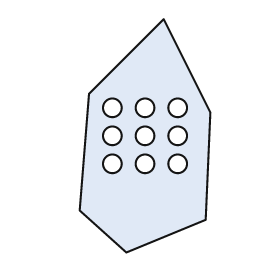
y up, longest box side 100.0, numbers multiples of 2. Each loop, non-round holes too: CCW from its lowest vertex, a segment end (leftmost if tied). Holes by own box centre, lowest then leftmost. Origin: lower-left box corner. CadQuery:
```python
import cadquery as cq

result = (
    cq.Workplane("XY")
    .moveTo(20.0, 0.0)
    .lineTo(54.0, 14.0)
    .lineTo(56.0, 60.0)
    .lineTo(36.0, 100.0)
    .lineTo(4.0, 68.0)
    .lineTo(0.0, 18.0)
    .close()
    .moveTo(14.0, 38.0)
    .circle(4.0)
    .moveTo(28.0, 38.0)
    .circle(4.0)
    .moveTo(42.0, 38.0)
    .circle(4.0)
    .moveTo(14.0, 50.0)
    .circle(4.0)
    .moveTo(28.0, 50.0)
    .circle(4.0)
    .moveTo(42.0, 50.0)
    .circle(4.0)
    .moveTo(14.0, 62.0)
    .circle(4.0)
    .moveTo(28.0, 62.0)
    .circle(4.0)
    .moveTo(42.0, 62.0)
    .circle(4.0)
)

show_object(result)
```